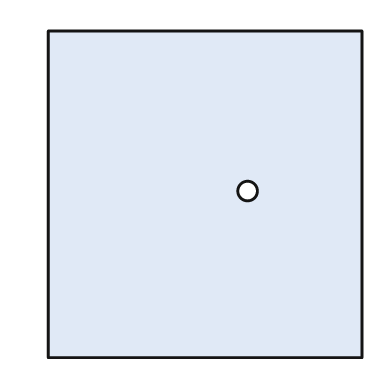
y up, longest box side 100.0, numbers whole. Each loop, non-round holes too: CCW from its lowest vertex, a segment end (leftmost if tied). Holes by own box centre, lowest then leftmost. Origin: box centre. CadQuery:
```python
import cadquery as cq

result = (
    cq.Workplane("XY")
    .moveTo(-48.0, -50.0)
    .lineTo(48.0, -50.0)
    .lineTo(48.0, 50.0)
    .lineTo(-48.0, 50.0)
    .close()
    .moveTo(13.0, 1.0)
    .circle(3.0)
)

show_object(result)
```